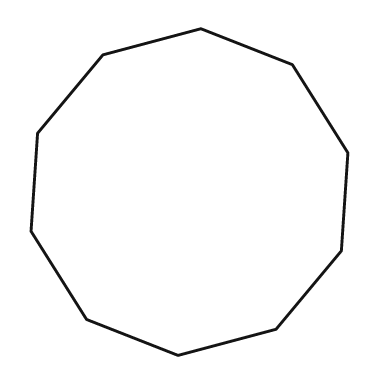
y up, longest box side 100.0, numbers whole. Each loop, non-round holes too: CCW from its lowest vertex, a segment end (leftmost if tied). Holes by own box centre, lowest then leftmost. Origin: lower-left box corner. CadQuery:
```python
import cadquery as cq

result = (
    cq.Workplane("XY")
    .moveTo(45.0, 0.0)
    .lineTo(75.0, 8.0)
    .lineTo(95.0, 32.0)
    .lineTo(97.0, 62.0)
    .lineTo(80.0, 89.0)
    .lineTo(52.0, 100.0)
    .lineTo(22.0, 92.0)
    .lineTo(2.0, 68.0)
    .lineTo(0.0, 38.0)
    .lineTo(17.0, 11.0)
    .close()
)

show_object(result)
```